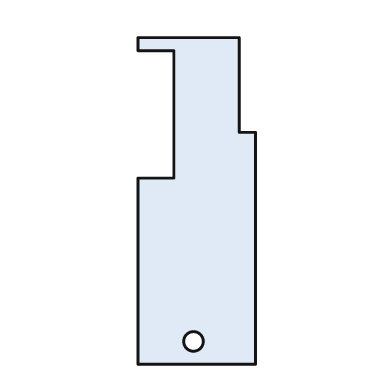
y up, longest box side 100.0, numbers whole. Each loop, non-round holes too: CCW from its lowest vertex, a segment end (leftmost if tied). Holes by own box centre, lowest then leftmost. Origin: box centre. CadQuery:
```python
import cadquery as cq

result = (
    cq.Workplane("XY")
    .moveTo(-18.0, -50.0)
    .lineTo(18.0, -50.0)
    .lineTo(18.0, 21.0)
    .lineTo(13.0, 21.0)
    .lineTo(13.0, 50.0)
    .lineTo(-18.0, 50.0)
    .lineTo(-18.0, 46.0)
    .lineTo(-7.0, 46.0)
    .lineTo(-7.0, 7.0)
    .lineTo(-18.0, 7.0)
    .close()
    .moveTo(-1.0, -43.0)
    .circle(3.0)
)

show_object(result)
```